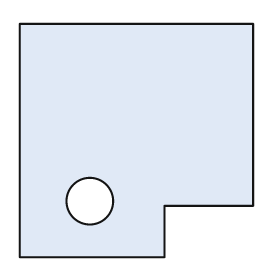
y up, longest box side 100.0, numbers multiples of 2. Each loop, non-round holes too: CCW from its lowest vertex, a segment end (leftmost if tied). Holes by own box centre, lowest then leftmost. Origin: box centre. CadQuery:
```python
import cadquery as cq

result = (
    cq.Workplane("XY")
    .moveTo(-50.0, -50.0)
    .lineTo(12.0, -50.0)
    .lineTo(12.0, -28.0)
    .lineTo(50.0, -28.0)
    .lineTo(50.0, 50.0)
    .lineTo(-50.0, 50.0)
    .close()
    .moveTo(-20.0, -26.0)
    .circle(10.0)
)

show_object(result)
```